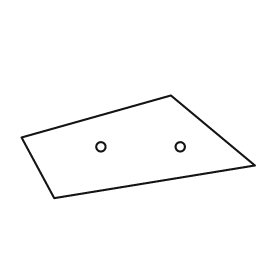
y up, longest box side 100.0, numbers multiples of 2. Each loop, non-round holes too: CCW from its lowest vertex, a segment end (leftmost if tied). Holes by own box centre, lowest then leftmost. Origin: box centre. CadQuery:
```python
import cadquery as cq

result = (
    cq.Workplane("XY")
    .moveTo(-36.0, -22.0)
    .lineTo(50.0, -8.0)
    .lineTo(14.0, 22.0)
    .lineTo(-50.0, 4.0)
    .close()
    .moveTo(-16.0, 0.0)
    .circle(2.0)
    .moveTo(18.0, 0.0)
    .circle(2.0)
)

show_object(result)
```